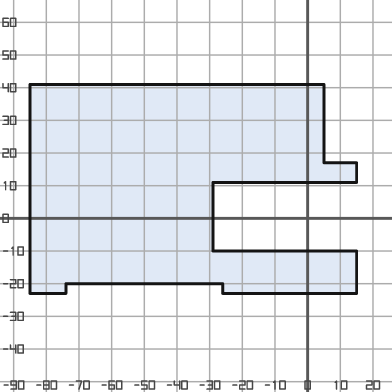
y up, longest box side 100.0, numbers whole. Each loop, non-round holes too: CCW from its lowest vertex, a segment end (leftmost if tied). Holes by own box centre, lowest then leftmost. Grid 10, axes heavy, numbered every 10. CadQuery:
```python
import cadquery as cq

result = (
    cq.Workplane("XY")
    .moveTo(-85.0, -23.0)
    .lineTo(-74.0, -23.0)
    .lineTo(-74.0, -20.0)
    .lineTo(-26.0, -20.0)
    .lineTo(-26.0, -23.0)
    .lineTo(15.0, -23.0)
    .lineTo(15.0, -10.0)
    .lineTo(-29.0, -10.0)
    .lineTo(-29.0, 11.0)
    .lineTo(15.0, 11.0)
    .lineTo(15.0, 17.0)
    .lineTo(5.0, 17.0)
    .lineTo(5.0, 41.0)
    .lineTo(-85.0, 41.0)
    .close()
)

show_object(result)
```